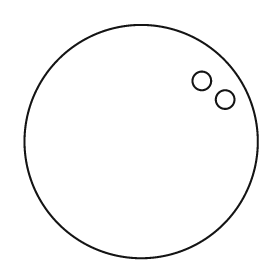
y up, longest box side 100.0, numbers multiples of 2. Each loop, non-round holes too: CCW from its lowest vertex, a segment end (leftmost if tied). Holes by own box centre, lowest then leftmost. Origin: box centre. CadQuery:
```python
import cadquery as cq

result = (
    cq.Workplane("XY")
    .moveTo(0.0, 0.0)
    .circle(50.0)
    .moveTo(36.0, 18.0)
    .circle(4.0)
    .moveTo(26.0, 26.0)
    .circle(4.0)
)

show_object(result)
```